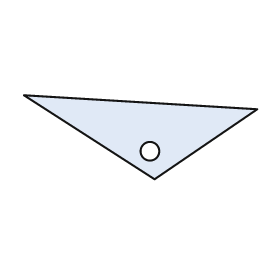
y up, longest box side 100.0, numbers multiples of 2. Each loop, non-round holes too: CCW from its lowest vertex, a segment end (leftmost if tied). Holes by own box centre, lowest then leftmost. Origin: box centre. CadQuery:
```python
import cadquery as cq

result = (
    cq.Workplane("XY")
    .moveTo(6.0, -18.0)
    .lineTo(50.0, 12.0)
    .lineTo(-50.0, 18.0)
    .close()
    .moveTo(4.0, -6.0)
    .circle(4.0)
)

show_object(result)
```